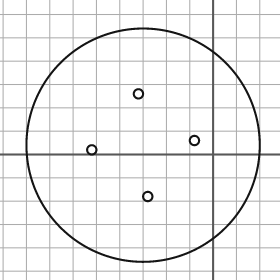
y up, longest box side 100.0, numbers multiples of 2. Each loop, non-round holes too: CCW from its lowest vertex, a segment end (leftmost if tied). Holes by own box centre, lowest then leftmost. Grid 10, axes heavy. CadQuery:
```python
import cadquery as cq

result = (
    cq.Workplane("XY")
    .moveTo(-30.0, 4.0)
    .circle(50.0)
    .moveTo(-28.0, -18.0)
    .circle(2.0)
    .moveTo(-52.0, 2.0)
    .circle(2.0)
    .moveTo(-8.0, 6.0)
    .circle(2.0)
    .moveTo(-32.0, 26.0)
    .circle(2.0)
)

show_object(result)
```